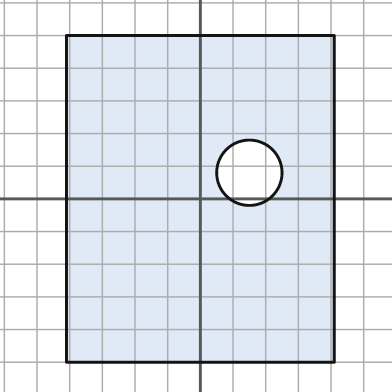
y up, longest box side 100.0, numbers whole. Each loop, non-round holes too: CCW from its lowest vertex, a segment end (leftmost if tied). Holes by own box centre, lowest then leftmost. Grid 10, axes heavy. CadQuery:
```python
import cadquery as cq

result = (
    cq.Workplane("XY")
    .moveTo(-41.0, -50.0)
    .lineTo(41.0, -50.0)
    .lineTo(41.0, 50.0)
    .lineTo(-41.0, 50.0)
    .close()
    .moveTo(15.0, 8.0)
    .circle(10.0)
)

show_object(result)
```